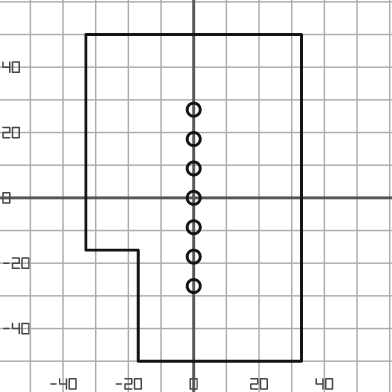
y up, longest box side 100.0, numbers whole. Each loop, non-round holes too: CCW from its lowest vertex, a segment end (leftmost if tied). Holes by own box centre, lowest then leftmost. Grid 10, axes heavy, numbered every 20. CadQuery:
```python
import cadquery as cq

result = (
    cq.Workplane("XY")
    .moveTo(-17.0, -50.0)
    .lineTo(33.0, -50.0)
    .lineTo(33.0, 50.0)
    .lineTo(-33.0, 50.0)
    .lineTo(-33.0, -16.0)
    .lineTo(-17.0, -16.0)
    .close()
    .moveTo(0.0, -27.0)
    .circle(2.0)
    .moveTo(0.0, -18.0)
    .circle(2.0)
    .moveTo(0.0, -9.0)
    .circle(2.0)
    .moveTo(0.0, 0.0)
    .circle(2.0)
    .moveTo(0.0, 9.0)
    .circle(2.0)
    .moveTo(0.0, 18.0)
    .circle(2.0)
    .moveTo(0.0, 27.0)
    .circle(2.0)
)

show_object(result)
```